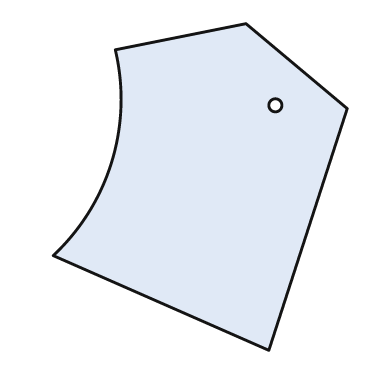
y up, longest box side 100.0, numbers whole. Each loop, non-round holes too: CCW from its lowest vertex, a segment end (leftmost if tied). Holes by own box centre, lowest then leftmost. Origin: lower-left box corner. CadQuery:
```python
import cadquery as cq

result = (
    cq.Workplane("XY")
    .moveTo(66.0, 0.0)
    .lineTo(90.0, 74.0)
    .lineTo(59.0, 100.0)
    .lineTo(19.0, 92.0)
    .threePointArc((18.0, 58.0), (0.0, 29.0))
    .close()
    .moveTo(68.0, 75.0)
    .circle(2.0)
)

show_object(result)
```